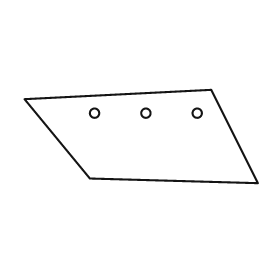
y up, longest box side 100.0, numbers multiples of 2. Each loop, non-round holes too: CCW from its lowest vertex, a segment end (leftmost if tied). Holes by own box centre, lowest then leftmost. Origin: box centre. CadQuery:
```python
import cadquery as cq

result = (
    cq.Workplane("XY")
    .moveTo(50.0, -20.0)
    .lineTo(30.0, 20.0)
    .lineTo(-50.0, 16.0)
    .lineTo(-22.0, -18.0)
    .close()
    .moveTo(-20.0, 10.0)
    .circle(2.0)
    .moveTo(2.0, 10.0)
    .circle(2.0)
    .moveTo(24.0, 10.0)
    .circle(2.0)
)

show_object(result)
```